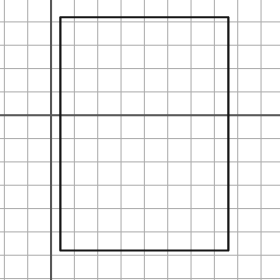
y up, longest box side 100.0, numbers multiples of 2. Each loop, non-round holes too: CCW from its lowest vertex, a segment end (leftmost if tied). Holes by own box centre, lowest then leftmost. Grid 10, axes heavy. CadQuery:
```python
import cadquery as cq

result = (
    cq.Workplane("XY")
    .moveTo(4.0, -58.0)
    .lineTo(76.0, -58.0)
    .lineTo(76.0, 42.0)
    .lineTo(4.0, 42.0)
    .close()
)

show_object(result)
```